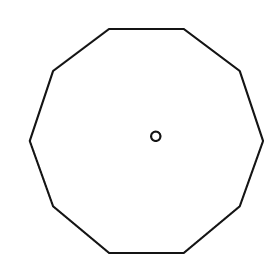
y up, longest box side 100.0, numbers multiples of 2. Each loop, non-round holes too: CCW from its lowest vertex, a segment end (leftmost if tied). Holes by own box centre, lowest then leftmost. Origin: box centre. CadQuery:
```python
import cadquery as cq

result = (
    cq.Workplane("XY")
    .moveTo(-16.0, -48.0)
    .lineTo(16.0, -48.0)
    .lineTo(40.0, -28.0)
    .lineTo(50.0, 0.0)
    .lineTo(40.0, 30.0)
    .lineTo(16.0, 48.0)
    .lineTo(-16.0, 48.0)
    .lineTo(-40.0, 30.0)
    .lineTo(-50.0, 0.0)
    .lineTo(-40.0, -28.0)
    .close()
    .moveTo(4.0, 2.0)
    .circle(2.0)
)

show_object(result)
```